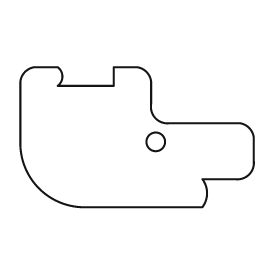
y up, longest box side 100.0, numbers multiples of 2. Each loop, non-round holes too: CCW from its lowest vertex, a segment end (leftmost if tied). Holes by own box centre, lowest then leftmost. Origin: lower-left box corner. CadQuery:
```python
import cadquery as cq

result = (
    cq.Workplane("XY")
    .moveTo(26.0, 0.0)
    .lineTo(78.0, 0.0)
    .threePointArc((80.0, 6.0), (78.0, 12.0))
    .lineTo(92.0, 12.0)
    .threePointArc((98.0, 14.0), (100.0, 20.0))
    .lineTo(100.0, 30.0)
    .threePointArc((98.0, 34.0), (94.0, 36.0))
    .lineTo(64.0, 36.0)
    .threePointArc((58.0, 38.0), (56.0, 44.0))
    .lineTo(56.0, 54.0)
    .threePointArc((54.0, 58.0), (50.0, 60.0))
    .lineTo(40.0, 60.0)
    .lineTo(40.0, 52.0)
    .lineTo(16.0, 52.0)
    .threePointArc((18.0, 56.0), (16.0, 60.0))
    .lineTo(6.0, 60.0)
    .threePointArc((2.0, 58.0), (0.0, 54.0))
    .lineTo(0.0, 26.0)
    .threePointArc((8.0, 8.0), (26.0, 0.0))
    .close()
    .moveTo(58.0, 28.0)
    .circle(4.0)
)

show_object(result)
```